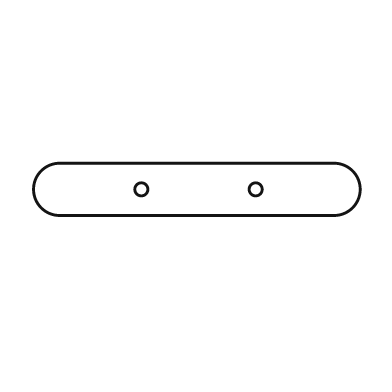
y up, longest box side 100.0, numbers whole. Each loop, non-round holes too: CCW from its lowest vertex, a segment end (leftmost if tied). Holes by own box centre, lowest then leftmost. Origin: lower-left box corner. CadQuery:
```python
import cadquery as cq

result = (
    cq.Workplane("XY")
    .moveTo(8.0, 0.0)
    .lineTo(92.0, 0.0)
    .threePointArc((100.0, 8.0), (92.0, 16.0))
    .lineTo(8.0, 16.0)
    .threePointArc((0.0, 8.0), (8.0, 0.0))
    .close()
    .moveTo(33.0, 8.0)
    .circle(2.0)
    .moveTo(68.0, 8.0)
    .circle(2.0)
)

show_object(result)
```